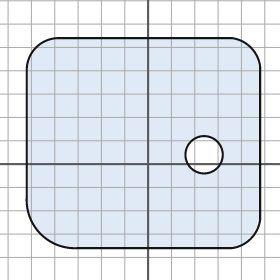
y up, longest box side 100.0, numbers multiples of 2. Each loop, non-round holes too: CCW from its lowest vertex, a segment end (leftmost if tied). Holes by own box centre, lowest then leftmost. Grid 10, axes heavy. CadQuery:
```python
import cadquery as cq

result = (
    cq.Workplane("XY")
    .moveTo(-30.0, -36.0)
    .lineTo(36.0, -36.0)
    .threePointArc((44.0, -32.0), (48.0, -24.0))
    .lineTo(48.0, 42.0)
    .threePointArc((44.0, 50.0), (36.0, 54.0))
    .lineTo(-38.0, 54.0)
    .threePointArc((-48.0, 50.0), (-52.0, 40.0))
    .lineTo(-52.0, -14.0)
    .threePointArc((-46.0, -30.0), (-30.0, -36.0))
    .close()
    .moveTo(24.0, 4.0)
    .circle(8.0)
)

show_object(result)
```